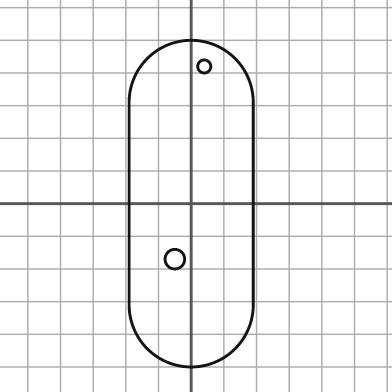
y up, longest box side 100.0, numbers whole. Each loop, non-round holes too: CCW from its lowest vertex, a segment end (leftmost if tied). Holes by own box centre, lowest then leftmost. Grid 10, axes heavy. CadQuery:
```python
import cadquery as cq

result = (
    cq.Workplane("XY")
    .moveTo(-19.0, -31.0)
    .threePointArc((0.0, -50.0), (19.0, -31.0))
    .lineTo(19.0, 31.0)
    .threePointArc((0.0, 50.0), (-19.0, 31.0))
    .close()
    .moveTo(-5.0, -17.0)
    .circle(3.0)
    .moveTo(4.0, 42.0)
    .circle(2.0)
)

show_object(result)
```